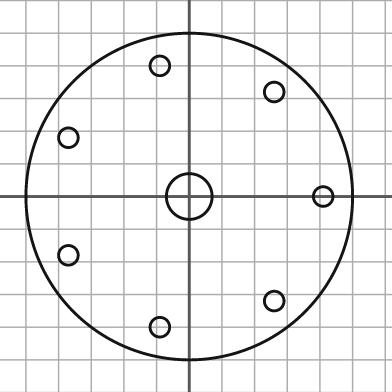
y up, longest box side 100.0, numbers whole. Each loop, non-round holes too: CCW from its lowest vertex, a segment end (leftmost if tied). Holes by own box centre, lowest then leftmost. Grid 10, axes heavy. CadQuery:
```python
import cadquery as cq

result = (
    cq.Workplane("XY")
    .moveTo(0.0, 0.0)
    .circle(50.0)
    .moveTo(-9.0, -40.0)
    .circle(3.0)
    .moveTo(26.0, -32.0)
    .circle(3.0)
    .moveTo(-37.0, -18.0)
    .circle(3.0)
    .moveTo(0.0, 0.0)
    .circle(7.0)
    .moveTo(41.0, 0.0)
    .circle(3.0)
    .moveTo(-37.0, 18.0)
    .circle(3.0)
    .moveTo(26.0, 32.0)
    .circle(3.0)
    .moveTo(-9.0, 40.0)
    .circle(3.0)
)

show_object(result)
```